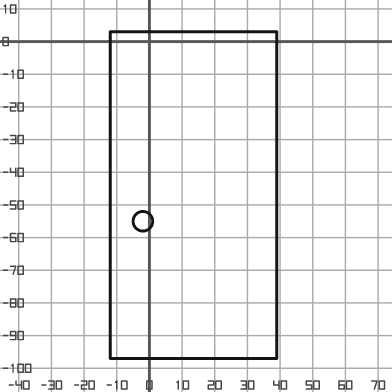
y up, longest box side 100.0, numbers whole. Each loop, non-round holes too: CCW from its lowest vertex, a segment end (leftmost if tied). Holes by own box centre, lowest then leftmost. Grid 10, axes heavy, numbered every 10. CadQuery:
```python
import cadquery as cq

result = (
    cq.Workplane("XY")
    .moveTo(-12.0, -97.0)
    .lineTo(39.0, -97.0)
    .lineTo(39.0, 3.0)
    .lineTo(-12.0, 3.0)
    .close()
    .moveTo(-2.0, -55.0)
    .circle(3.0)
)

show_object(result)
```